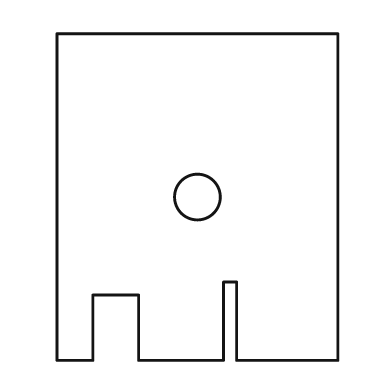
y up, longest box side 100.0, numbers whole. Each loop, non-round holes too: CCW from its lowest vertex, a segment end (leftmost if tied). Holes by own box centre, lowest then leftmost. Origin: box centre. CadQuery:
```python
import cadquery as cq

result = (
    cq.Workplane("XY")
    .moveTo(-43.0, -50.0)
    .lineTo(-32.0, -50.0)
    .lineTo(-32.0, -30.0)
    .lineTo(-18.0, -30.0)
    .lineTo(-18.0, -50.0)
    .lineTo(8.0, -50.0)
    .lineTo(8.0, -26.0)
    .lineTo(12.0, -26.0)
    .lineTo(12.0, -50.0)
    .lineTo(43.0, -50.0)
    .lineTo(43.0, 50.0)
    .lineTo(-43.0, 50.0)
    .close()
    .moveTo(0.0, 0.0)
    .circle(7.0)
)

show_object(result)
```